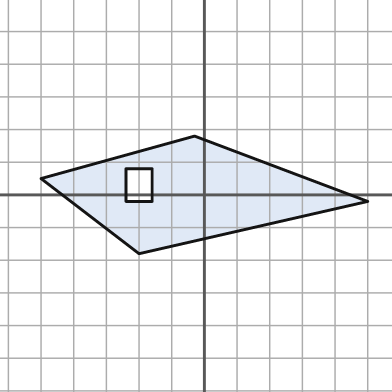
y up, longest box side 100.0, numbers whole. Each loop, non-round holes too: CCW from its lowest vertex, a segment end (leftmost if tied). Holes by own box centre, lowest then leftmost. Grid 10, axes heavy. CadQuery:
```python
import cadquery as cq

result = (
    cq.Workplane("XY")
    .moveTo(-20.0, -18.0)
    .lineTo(50.0, -2.0)
    .lineTo(-3.0, 18.0)
    .lineTo(-50.0, 5.0)
    .close()
    .moveTo(-24.0, -2.0)
    .lineTo(-16.0, -2.0)
    .lineTo(-16.0, 8.0)
    .lineTo(-24.0, 8.0)
    .close()
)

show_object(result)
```